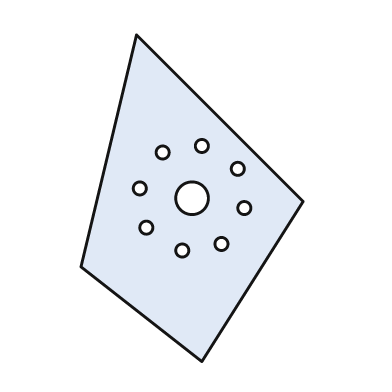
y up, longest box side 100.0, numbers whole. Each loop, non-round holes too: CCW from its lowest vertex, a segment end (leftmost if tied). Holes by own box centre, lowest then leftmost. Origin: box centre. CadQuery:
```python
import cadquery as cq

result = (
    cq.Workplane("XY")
    .moveTo(3.0, -50.0)
    .lineTo(34.0, -1.0)
    .lineTo(-17.0, 50.0)
    .lineTo(-34.0, -21.0)
    .close()
    .moveTo(-3.0, -16.0)
    .circle(2.0)
    .moveTo(9.0, -14.0)
    .circle(2.0)
    .moveTo(-14.0, -9.0)
    .circle(2.0)
    .moveTo(16.0, -3.0)
    .circle(2.0)
    .moveTo(0.0, 0.0)
    .circle(5.0)
    .moveTo(-16.0, 3.0)
    .circle(2.0)
    .moveTo(14.0, 9.0)
    .circle(2.0)
    .moveTo(-9.0, 14.0)
    .circle(2.0)
    .moveTo(3.0, 16.0)
    .circle(2.0)
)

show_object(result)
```